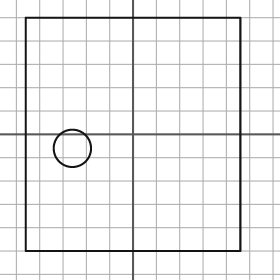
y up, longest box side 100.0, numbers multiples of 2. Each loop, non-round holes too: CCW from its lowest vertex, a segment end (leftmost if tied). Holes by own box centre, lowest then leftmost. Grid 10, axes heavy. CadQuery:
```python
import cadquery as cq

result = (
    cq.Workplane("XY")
    .moveTo(-46.0, -50.0)
    .lineTo(46.0, -50.0)
    .lineTo(46.0, 50.0)
    .lineTo(-46.0, 50.0)
    .close()
    .moveTo(-26.0, -6.0)
    .circle(8.0)
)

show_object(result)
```